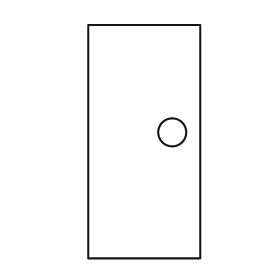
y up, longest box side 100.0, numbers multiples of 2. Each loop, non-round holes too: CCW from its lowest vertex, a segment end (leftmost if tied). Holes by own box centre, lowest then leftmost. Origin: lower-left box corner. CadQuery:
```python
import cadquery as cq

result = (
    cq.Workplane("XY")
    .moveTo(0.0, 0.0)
    .lineTo(48.0, 0.0)
    .lineTo(48.0, 100.0)
    .lineTo(0.0, 100.0)
    .close()
    .moveTo(36.0, 54.0)
    .circle(6.0)
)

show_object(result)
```